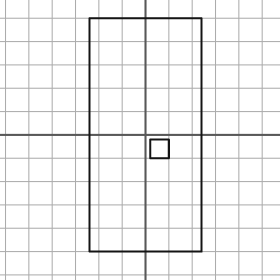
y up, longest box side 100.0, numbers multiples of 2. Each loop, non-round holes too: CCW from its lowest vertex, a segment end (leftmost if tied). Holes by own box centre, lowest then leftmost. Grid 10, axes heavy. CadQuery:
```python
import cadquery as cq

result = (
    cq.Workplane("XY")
    .moveTo(-24.0, -50.0)
    .lineTo(24.0, -50.0)
    .lineTo(24.0, 50.0)
    .lineTo(-24.0, 50.0)
    .close()
    .moveTo(2.0, -10.0)
    .lineTo(10.0, -10.0)
    .lineTo(10.0, -2.0)
    .lineTo(2.0, -2.0)
    .close()
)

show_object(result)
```